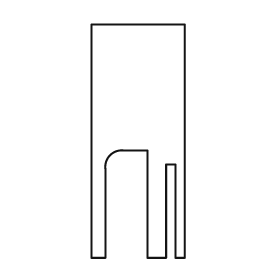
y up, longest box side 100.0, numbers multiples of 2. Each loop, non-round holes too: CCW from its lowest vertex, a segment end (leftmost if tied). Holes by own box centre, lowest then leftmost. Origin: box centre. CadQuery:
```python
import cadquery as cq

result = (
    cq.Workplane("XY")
    .moveTo(-20.0, -50.0)
    .lineTo(-14.0, -50.0)
    .lineTo(-14.0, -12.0)
    .threePointArc((-12.0, -6.0), (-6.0, -4.0))
    .lineTo(4.0, -4.0)
    .lineTo(4.0, -50.0)
    .lineTo(12.0, -50.0)
    .lineTo(12.0, -10.0)
    .lineTo(16.0, -10.0)
    .lineTo(16.0, -50.0)
    .lineTo(20.0, -50.0)
    .lineTo(20.0, 50.0)
    .lineTo(-20.0, 50.0)
    .close()
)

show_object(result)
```